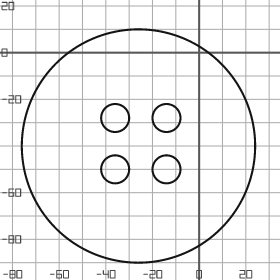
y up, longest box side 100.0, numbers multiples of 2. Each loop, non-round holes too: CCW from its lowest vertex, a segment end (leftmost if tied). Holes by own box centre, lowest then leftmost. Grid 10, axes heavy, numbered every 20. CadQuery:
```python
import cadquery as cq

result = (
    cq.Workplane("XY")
    .moveTo(-26.0, -40.0)
    .circle(50.0)
    .moveTo(-36.0, -50.0)
    .circle(6.0)
    .moveTo(-14.0, -50.0)
    .circle(6.0)
    .moveTo(-36.0, -28.0)
    .circle(6.0)
    .moveTo(-14.0, -28.0)
    .circle(6.0)
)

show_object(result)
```